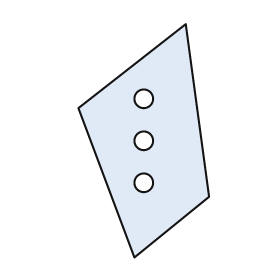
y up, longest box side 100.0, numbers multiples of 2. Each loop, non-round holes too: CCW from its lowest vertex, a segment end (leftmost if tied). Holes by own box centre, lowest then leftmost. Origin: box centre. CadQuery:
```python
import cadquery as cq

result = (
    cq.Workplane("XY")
    .moveTo(-4.0, -50.0)
    .lineTo(28.0, -24.0)
    .lineTo(18.0, 50.0)
    .lineTo(-28.0, 14.0)
    .close()
    .moveTo(0.0, -18.0)
    .circle(4.0)
    .moveTo(0.0, 0.0)
    .circle(4.0)
    .moveTo(0.0, 18.0)
    .circle(4.0)
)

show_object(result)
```